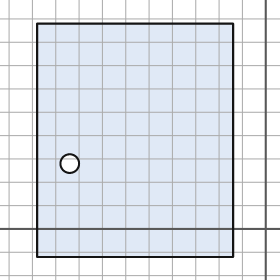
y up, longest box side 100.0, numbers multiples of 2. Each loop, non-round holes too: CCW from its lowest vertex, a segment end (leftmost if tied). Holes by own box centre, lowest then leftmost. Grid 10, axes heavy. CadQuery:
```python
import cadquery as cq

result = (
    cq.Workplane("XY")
    .moveTo(-98.0, -12.0)
    .lineTo(-14.0, -12.0)
    .lineTo(-14.0, 88.0)
    .lineTo(-98.0, 88.0)
    .close()
    .moveTo(-84.0, 28.0)
    .circle(4.0)
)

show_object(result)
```